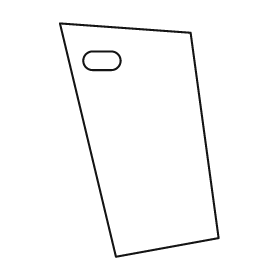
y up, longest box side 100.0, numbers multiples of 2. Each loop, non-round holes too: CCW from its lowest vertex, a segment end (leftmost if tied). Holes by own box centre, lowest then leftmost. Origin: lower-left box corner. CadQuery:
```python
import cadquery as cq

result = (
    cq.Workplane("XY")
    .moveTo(24.0, 0.0)
    .lineTo(68.0, 8.0)
    .lineTo(56.0, 96.0)
    .lineTo(0.0, 100.0)
    .close()
    .moveTo(14.0, 80.0)
    .lineTo(22.0, 80.0)
    .threePointArc((26.0, 84.0), (22.0, 88.0))
    .lineTo(14.0, 88.0)
    .threePointArc((10.0, 84.0), (14.0, 80.0))
    .close()
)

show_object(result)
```